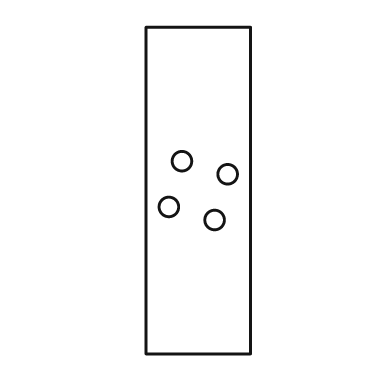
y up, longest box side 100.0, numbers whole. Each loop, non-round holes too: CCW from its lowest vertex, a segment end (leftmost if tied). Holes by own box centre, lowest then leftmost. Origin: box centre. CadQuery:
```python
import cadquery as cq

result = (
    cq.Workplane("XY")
    .moveTo(-16.0, -50.0)
    .lineTo(16.0, -50.0)
    .lineTo(16.0, 50.0)
    .lineTo(-16.0, 50.0)
    .close()
    .moveTo(5.0, -9.0)
    .circle(3.0)
    .moveTo(-9.0, -5.0)
    .circle(3.0)
    .moveTo(9.0, 5.0)
    .circle(3.0)
    .moveTo(-5.0, 9.0)
    .circle(3.0)
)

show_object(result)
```